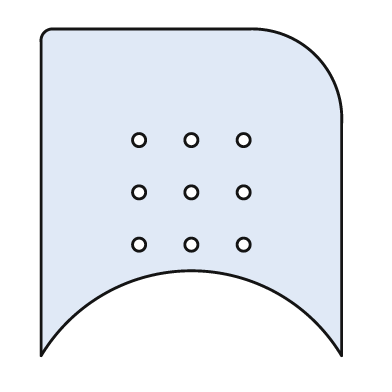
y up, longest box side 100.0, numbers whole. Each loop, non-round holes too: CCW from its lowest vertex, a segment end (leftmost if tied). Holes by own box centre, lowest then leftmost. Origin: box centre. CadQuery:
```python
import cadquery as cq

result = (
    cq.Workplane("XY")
    .moveTo(-46.0, -50.0)
    .threePointArc((0.0, -24.0), (46.0, -50.0))
    .lineTo(46.0, 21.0)
    .threePointArc((38.0, 42.0), (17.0, 50.0))
    .lineTo(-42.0, 50.0)
    .threePointArc((-45.0, 49.0), (-46.0, 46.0))
    .close()
    .moveTo(-16.0, -16.0)
    .circle(2.0)
    .moveTo(0.0, -16.0)
    .circle(2.0)
    .moveTo(16.0, -16.0)
    .circle(2.0)
    .moveTo(-16.0, 0.0)
    .circle(2.0)
    .moveTo(0.0, 0.0)
    .circle(2.0)
    .moveTo(16.0, 0.0)
    .circle(2.0)
    .moveTo(-16.0, 16.0)
    .circle(2.0)
    .moveTo(0.0, 16.0)
    .circle(2.0)
    .moveTo(16.0, 16.0)
    .circle(2.0)
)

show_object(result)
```